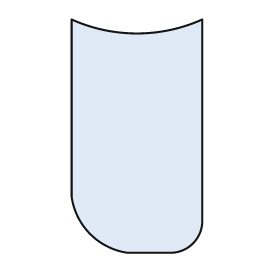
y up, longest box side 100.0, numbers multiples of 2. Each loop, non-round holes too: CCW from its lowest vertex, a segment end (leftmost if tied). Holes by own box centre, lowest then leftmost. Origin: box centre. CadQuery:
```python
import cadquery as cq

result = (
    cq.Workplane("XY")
    .moveTo(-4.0, -50.0)
    .lineTo(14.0, -50.0)
    .threePointArc((24.0, -46.0), (28.0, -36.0))
    .lineTo(28.0, 50.0)
    .threePointArc((0.0, 44.0), (-28.0, 50.0))
    .lineTo(-28.0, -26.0)
    .threePointArc((-20.0, -42.0), (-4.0, -50.0))
    .close()
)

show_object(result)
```